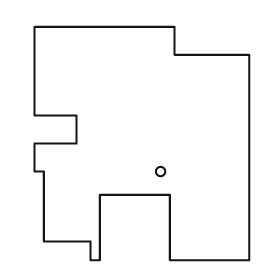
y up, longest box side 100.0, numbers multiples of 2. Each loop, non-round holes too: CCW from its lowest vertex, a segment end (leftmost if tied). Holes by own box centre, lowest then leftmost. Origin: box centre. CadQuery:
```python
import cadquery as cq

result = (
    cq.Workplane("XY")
    .moveTo(-22.0, -50.0)
    .lineTo(-18.0, -50.0)
    .lineTo(-18.0, -22.0)
    .lineTo(12.0, -22.0)
    .lineTo(12.0, -50.0)
    .lineTo(46.0, -50.0)
    .lineTo(46.0, 38.0)
    .lineTo(14.0, 38.0)
    .lineTo(14.0, 50.0)
    .lineTo(-46.0, 50.0)
    .lineTo(-46.0, 12.0)
    .lineTo(-28.0, 12.0)
    .lineTo(-28.0, 0.0)
    .lineTo(-46.0, 0.0)
    .lineTo(-46.0, -12.0)
    .lineTo(-42.0, -12.0)
    .lineTo(-42.0, -42.0)
    .lineTo(-22.0, -42.0)
    .close()
    .moveTo(8.0, -12.0)
    .circle(2.0)
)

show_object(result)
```